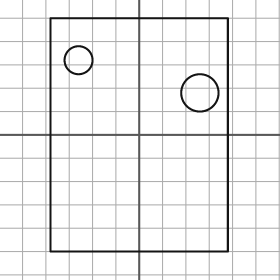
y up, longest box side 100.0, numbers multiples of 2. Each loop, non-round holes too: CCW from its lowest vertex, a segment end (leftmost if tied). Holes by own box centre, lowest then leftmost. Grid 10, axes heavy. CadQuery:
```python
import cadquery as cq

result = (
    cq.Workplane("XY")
    .moveTo(-38.0, -50.0)
    .lineTo(38.0, -50.0)
    .lineTo(38.0, 50.0)
    .lineTo(-38.0, 50.0)
    .close()
    .moveTo(26.0, 18.0)
    .circle(8.0)
    .moveTo(-26.0, 32.0)
    .circle(6.0)
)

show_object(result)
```